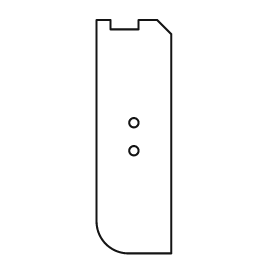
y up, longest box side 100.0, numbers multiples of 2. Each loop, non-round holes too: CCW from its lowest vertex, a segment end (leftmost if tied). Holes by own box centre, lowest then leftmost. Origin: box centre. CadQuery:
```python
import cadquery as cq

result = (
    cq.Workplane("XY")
    .moveTo(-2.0, -50.0)
    .lineTo(16.0, -50.0)
    .lineTo(16.0, 44.0)
    .lineTo(10.0, 50.0)
    .lineTo(2.0, 50.0)
    .lineTo(2.0, 46.0)
    .lineTo(-10.0, 46.0)
    .lineTo(-10.0, 50.0)
    .lineTo(-16.0, 50.0)
    .lineTo(-16.0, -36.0)
    .threePointArc((-12.0, -46.0), (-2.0, -50.0))
    .close()
    .moveTo(0.0, -6.0)
    .circle(2.0)
    .moveTo(0.0, 6.0)
    .circle(2.0)
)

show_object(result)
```